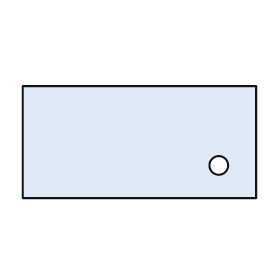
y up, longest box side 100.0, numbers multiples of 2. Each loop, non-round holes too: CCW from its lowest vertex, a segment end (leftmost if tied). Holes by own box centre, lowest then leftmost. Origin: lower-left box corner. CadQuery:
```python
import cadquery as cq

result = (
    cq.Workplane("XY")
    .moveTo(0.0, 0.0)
    .lineTo(100.0, 0.0)
    .lineTo(100.0, 48.0)
    .lineTo(0.0, 48.0)
    .close()
    .moveTo(84.0, 14.0)
    .circle(4.0)
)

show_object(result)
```